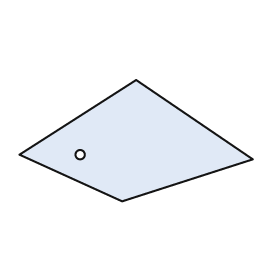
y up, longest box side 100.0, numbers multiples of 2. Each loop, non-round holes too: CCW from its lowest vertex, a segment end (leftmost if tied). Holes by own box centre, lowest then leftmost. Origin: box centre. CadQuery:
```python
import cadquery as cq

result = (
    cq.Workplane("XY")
    .moveTo(-6.0, -26.0)
    .lineTo(50.0, -8.0)
    .lineTo(0.0, 26.0)
    .lineTo(-50.0, -6.0)
    .close()
    .moveTo(-24.0, -6.0)
    .circle(2.0)
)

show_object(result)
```